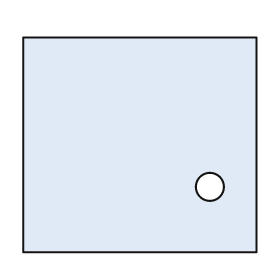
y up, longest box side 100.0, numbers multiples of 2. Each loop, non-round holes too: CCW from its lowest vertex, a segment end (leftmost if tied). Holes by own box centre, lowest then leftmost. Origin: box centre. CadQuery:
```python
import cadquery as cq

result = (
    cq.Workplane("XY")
    .moveTo(-50.0, -46.0)
    .lineTo(50.0, -46.0)
    .lineTo(50.0, 46.0)
    .lineTo(-50.0, 46.0)
    .close()
    .moveTo(30.0, -18.0)
    .circle(6.0)
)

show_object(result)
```